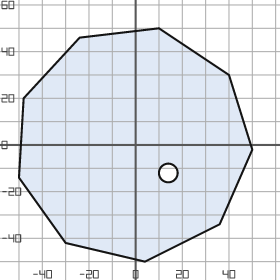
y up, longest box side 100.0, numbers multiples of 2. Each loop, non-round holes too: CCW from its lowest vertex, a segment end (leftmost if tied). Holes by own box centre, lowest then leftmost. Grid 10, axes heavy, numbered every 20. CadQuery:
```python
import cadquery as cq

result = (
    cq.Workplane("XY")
    .moveTo(4.0, -50.0)
    .lineTo(36.0, -34.0)
    .lineTo(50.0, -2.0)
    .lineTo(40.0, 30.0)
    .lineTo(10.0, 50.0)
    .lineTo(-24.0, 46.0)
    .lineTo(-48.0, 20.0)
    .lineTo(-50.0, -14.0)
    .lineTo(-30.0, -42.0)
    .close()
    .moveTo(14.0, -12.0)
    .circle(4.0)
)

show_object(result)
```